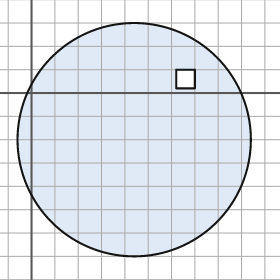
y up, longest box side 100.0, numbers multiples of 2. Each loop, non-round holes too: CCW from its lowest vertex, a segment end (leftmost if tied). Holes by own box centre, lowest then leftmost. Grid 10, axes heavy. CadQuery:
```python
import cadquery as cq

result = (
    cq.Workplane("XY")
    .moveTo(44.0, -20.0)
    .circle(50.0)
    .moveTo(62.0, 2.0)
    .lineTo(70.0, 2.0)
    .lineTo(70.0, 10.0)
    .lineTo(62.0, 10.0)
    .close()
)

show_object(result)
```